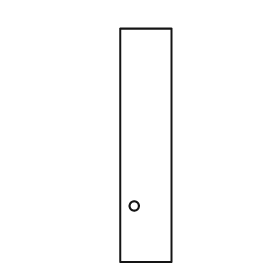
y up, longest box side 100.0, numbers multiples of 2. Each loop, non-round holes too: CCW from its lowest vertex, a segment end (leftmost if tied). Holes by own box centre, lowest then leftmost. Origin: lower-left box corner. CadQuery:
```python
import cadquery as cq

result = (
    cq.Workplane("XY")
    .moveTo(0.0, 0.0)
    .lineTo(22.0, 0.0)
    .lineTo(22.0, 100.0)
    .lineTo(0.0, 100.0)
    .close()
    .moveTo(6.0, 24.0)
    .circle(2.0)
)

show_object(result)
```